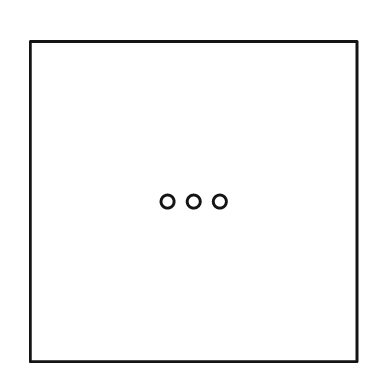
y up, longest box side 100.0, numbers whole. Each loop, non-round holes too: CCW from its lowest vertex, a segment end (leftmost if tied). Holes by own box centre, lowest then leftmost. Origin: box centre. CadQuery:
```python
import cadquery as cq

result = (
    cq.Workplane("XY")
    .moveTo(-50.0, -49.0)
    .lineTo(50.0, -49.0)
    .lineTo(50.0, 49.0)
    .lineTo(-50.0, 49.0)
    .close()
    .moveTo(-8.0, 0.0)
    .circle(2.0)
    .moveTo(0.0, 0.0)
    .circle(2.0)
    .moveTo(8.0, 0.0)
    .circle(2.0)
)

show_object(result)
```